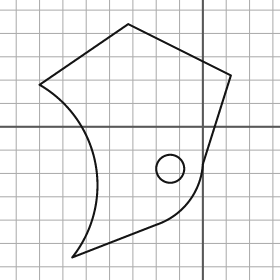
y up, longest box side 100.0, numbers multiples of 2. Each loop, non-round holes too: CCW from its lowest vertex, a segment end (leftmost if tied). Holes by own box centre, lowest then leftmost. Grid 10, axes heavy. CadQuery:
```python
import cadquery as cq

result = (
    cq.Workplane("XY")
    .moveTo(-56.0, -56.0)
    .lineTo(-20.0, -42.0)
    .threePointArc((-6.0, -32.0), (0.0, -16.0))
    .lineTo(12.0, 22.0)
    .lineTo(-32.0, 44.0)
    .lineTo(-70.0, 18.0)
    .threePointArc((-46.0, -16.0), (-56.0, -56.0))
    .close()
    .moveTo(-14.0, -18.0)
    .circle(6.0)
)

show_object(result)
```